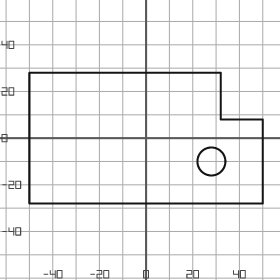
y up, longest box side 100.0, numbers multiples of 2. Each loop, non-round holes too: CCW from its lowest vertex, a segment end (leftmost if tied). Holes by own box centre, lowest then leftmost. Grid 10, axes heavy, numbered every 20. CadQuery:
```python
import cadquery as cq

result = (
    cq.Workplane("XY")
    .moveTo(-50.0, -28.0)
    .lineTo(50.0, -28.0)
    .lineTo(50.0, 8.0)
    .lineTo(32.0, 8.0)
    .lineTo(32.0, 28.0)
    .lineTo(-50.0, 28.0)
    .close()
    .moveTo(28.0, -10.0)
    .circle(6.0)
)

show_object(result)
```